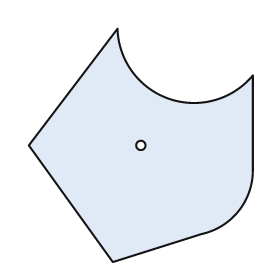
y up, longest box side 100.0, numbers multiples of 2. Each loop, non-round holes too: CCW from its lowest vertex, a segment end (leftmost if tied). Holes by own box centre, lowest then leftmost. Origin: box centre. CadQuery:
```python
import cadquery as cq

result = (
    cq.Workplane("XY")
    .moveTo(-12.0, -50.0)
    .lineTo(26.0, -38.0)
    .threePointArc((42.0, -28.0), (48.0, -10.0))
    .lineTo(48.0, 30.0)
    .threePointArc((12.0, 20.0), (-10.0, 50.0))
    .lineTo(-48.0, 0.0)
    .close()
    .moveTo(0.0, 0.0)
    .circle(2.0)
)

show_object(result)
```